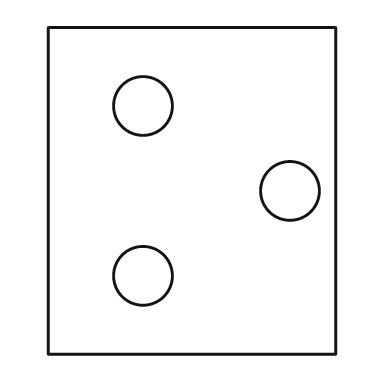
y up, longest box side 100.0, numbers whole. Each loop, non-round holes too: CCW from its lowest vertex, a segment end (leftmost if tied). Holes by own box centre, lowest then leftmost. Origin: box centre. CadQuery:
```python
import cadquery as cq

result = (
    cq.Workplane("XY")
    .moveTo(-44.0, -50.0)
    .lineTo(44.0, -50.0)
    .lineTo(44.0, 50.0)
    .lineTo(-44.0, 50.0)
    .close()
    .moveTo(-15.0, -26.0)
    .circle(9.0)
    .moveTo(30.0, 0.0)
    .circle(9.0)
    .moveTo(-15.0, 26.0)
    .circle(9.0)
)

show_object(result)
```